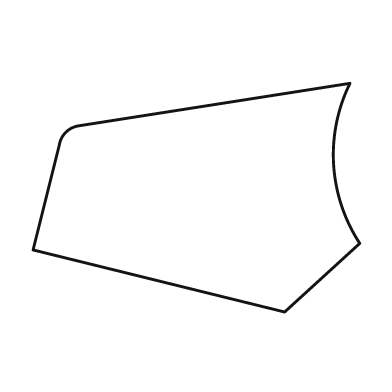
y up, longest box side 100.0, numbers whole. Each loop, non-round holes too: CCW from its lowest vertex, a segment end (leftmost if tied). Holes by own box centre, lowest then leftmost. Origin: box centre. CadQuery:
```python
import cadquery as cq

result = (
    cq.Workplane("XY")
    .moveTo(27.0, -35.0)
    .lineTo(50.0, -14.0)
    .threePointArc((42.0, 10.0), (47.0, 35.0))
    .lineTo(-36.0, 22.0)
    .threePointArc((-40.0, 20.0), (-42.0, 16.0))
    .lineTo(-50.0, -16.0)
    .close()
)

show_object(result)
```